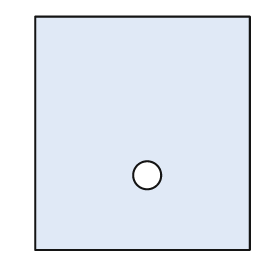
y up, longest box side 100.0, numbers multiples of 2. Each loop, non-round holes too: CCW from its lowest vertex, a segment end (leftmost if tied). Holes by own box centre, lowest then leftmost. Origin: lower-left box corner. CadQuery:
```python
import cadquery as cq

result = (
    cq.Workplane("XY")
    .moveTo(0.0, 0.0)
    .lineTo(92.0, 0.0)
    .lineTo(92.0, 100.0)
    .lineTo(0.0, 100.0)
    .close()
    .moveTo(48.0, 32.0)
    .circle(6.0)
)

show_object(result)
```